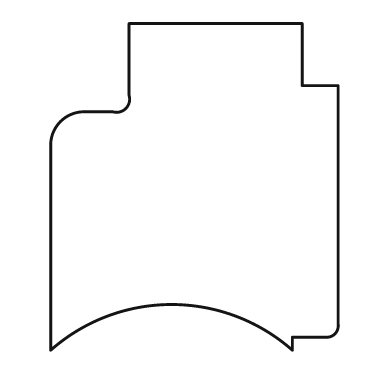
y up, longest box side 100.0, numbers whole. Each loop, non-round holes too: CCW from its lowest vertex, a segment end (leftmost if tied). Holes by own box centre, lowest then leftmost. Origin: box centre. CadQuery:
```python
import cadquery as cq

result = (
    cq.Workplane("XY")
    .moveTo(-44.0, -50.0)
    .threePointArc((-7.0, -36.0), (30.0, -50.0))
    .lineTo(30.0, -46.0)
    .lineTo(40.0, -46.0)
    .threePointArc((43.0, -45.0), (44.0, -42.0))
    .lineTo(44.0, 31.0)
    .lineTo(33.0, 31.0)
    .lineTo(33.0, 50.0)
    .lineTo(-20.0, 50.0)
    .lineTo(-20.0, 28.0)
    .threePointArc((-21.0, 24.0), (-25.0, 23.0))
    .lineTo(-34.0, 23.0)
    .threePointArc((-41.0, 20.0), (-44.0, 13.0))
    .close()
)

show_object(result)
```